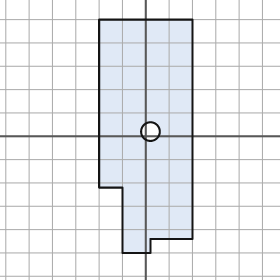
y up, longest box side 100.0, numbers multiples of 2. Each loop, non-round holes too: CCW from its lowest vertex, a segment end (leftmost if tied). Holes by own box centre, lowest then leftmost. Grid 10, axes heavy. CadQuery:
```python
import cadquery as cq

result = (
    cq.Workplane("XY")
    .moveTo(-10.0, -50.0)
    .lineTo(2.0, -50.0)
    .lineTo(2.0, -44.0)
    .lineTo(20.0, -44.0)
    .lineTo(20.0, 50.0)
    .lineTo(-20.0, 50.0)
    .lineTo(-20.0, -22.0)
    .lineTo(-10.0, -22.0)
    .close()
    .moveTo(2.0, 2.0)
    .circle(4.0)
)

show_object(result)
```